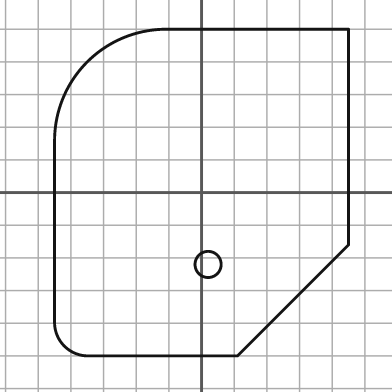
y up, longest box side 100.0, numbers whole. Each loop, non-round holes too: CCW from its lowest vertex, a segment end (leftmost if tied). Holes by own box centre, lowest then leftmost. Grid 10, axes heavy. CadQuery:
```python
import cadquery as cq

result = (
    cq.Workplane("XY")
    .moveTo(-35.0, -50.0)
    .lineTo(11.0, -50.0)
    .lineTo(45.0, -16.0)
    .lineTo(45.0, 50.0)
    .lineTo(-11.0, 50.0)
    .threePointArc((-35.0, 40.0), (-45.0, 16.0))
    .lineTo(-45.0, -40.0)
    .threePointArc((-42.0, -47.0), (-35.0, -50.0))
    .close()
    .moveTo(2.0, -22.0)
    .circle(4.0)
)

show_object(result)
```